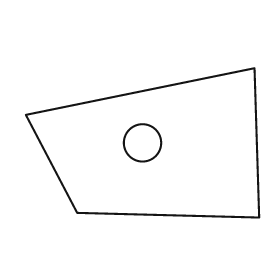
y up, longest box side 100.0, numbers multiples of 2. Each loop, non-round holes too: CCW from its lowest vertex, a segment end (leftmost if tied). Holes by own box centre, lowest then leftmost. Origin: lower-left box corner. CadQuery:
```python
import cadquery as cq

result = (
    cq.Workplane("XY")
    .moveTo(100.0, 0.0)
    .lineTo(98.0, 64.0)
    .lineTo(0.0, 44.0)
    .lineTo(22.0, 2.0)
    .close()
    .moveTo(50.0, 32.0)
    .circle(8.0)
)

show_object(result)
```